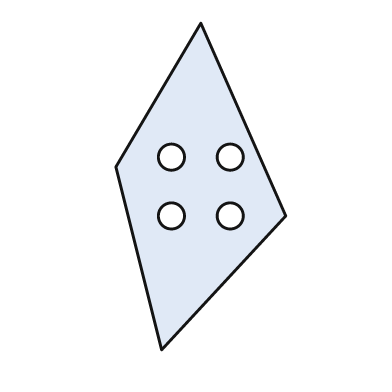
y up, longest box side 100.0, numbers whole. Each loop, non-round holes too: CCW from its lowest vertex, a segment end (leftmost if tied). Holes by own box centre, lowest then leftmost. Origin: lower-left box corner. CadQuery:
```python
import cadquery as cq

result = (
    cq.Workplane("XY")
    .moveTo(14.0, 0.0)
    .lineTo(52.0, 41.0)
    .lineTo(26.0, 100.0)
    .lineTo(0.0, 56.0)
    .close()
    .moveTo(17.0, 41.0)
    .circle(4.0)
    .moveTo(35.0, 41.0)
    .circle(4.0)
    .moveTo(17.0, 59.0)
    .circle(4.0)
    .moveTo(35.0, 59.0)
    .circle(4.0)
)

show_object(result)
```